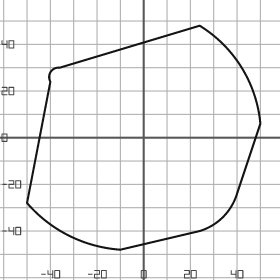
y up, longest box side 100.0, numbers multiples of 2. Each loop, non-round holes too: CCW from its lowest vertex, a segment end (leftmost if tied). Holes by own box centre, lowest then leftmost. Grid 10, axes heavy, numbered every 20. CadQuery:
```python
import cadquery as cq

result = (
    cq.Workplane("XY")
    .moveTo(-10.0, -48.0)
    .lineTo(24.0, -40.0)
    .threePointArc((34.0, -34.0), (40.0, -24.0))
    .lineTo(50.0, 6.0)
    .threePointArc((42.0, 30.0), (24.0, 48.0))
    .lineTo(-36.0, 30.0)
    .threePointArc((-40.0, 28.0), (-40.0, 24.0))
    .lineTo(-50.0, -28.0)
    .threePointArc((-32.0, -42.0), (-10.0, -48.0))
    .close()
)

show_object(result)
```